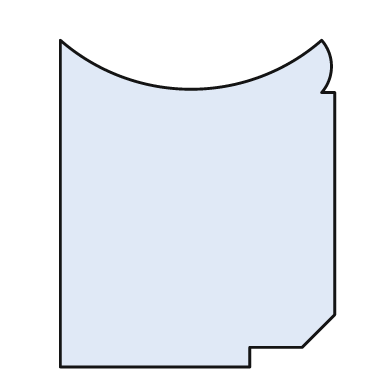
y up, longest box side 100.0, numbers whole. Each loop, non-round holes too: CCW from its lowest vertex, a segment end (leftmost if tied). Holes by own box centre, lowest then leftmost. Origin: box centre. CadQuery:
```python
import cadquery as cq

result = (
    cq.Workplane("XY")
    .moveTo(-42.0, -50.0)
    .lineTo(16.0, -50.0)
    .lineTo(16.0, -44.0)
    .lineTo(32.0, -44.0)
    .lineTo(42.0, -34.0)
    .lineTo(42.0, 34.0)
    .lineTo(38.0, 34.0)
    .threePointArc((41.0, 42.0), (38.0, 50.0))
    .threePointArc((-2.0, 35.0), (-42.0, 50.0))
    .close()
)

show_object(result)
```